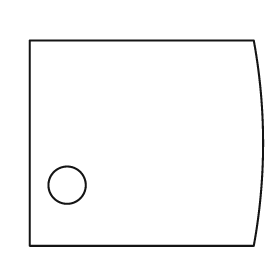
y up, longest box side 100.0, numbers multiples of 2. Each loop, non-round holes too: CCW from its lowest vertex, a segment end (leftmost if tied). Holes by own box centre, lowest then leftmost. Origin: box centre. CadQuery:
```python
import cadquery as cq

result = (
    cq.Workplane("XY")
    .moveTo(-50.0, -44.0)
    .lineTo(46.0, -44.0)
    .threePointArc((50.0, 0.0), (46.0, 44.0))
    .lineTo(-50.0, 44.0)
    .close()
    .moveTo(-34.0, -18.0)
    .circle(8.0)
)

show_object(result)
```